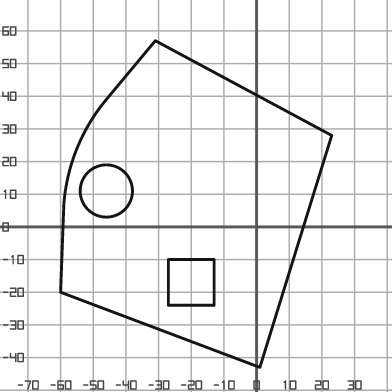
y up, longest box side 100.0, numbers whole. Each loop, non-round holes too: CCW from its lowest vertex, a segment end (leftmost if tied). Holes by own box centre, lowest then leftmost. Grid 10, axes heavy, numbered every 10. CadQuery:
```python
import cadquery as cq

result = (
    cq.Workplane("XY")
    .moveTo(1.0, -43.0)
    .lineTo(23.0, 28.0)
    .lineTo(-31.0, 57.0)
    .lineTo(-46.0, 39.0)
    .threePointArc((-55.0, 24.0), (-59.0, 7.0))
    .lineTo(-60.0, -20.0)
    .close()
    .moveTo(-27.0, -24.0)
    .lineTo(-13.0, -24.0)
    .lineTo(-13.0, -10.0)
    .lineTo(-27.0, -10.0)
    .close()
    .moveTo(-46.0, 11.0)
    .circle(8.0)
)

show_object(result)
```